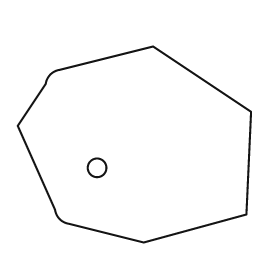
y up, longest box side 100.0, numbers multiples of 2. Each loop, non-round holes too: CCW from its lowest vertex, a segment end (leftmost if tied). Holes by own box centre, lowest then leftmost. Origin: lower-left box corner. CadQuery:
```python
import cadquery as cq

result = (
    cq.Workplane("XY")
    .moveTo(54.0, 0.0)
    .lineTo(98.0, 12.0)
    .lineTo(100.0, 56.0)
    .lineTo(58.0, 84.0)
    .lineTo(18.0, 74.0)
    .threePointArc((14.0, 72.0), (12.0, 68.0))
    .lineTo(0.0, 50.0)
    .lineTo(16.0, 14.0)
    .threePointArc((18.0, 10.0), (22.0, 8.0))
    .close()
    .moveTo(34.0, 32.0)
    .circle(4.0)
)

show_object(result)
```